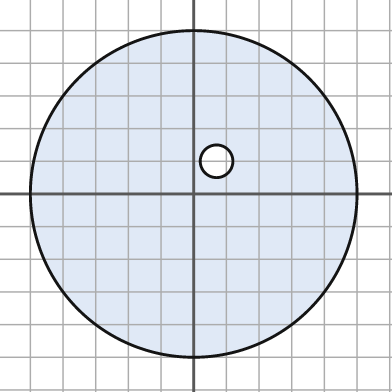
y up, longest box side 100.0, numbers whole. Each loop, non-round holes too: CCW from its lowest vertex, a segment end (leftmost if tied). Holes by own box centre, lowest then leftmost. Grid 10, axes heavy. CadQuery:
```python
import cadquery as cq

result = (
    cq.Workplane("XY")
    .moveTo(0.0, 0.0)
    .circle(50.0)
    .moveTo(7.0, 10.0)
    .circle(5.0)
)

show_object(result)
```